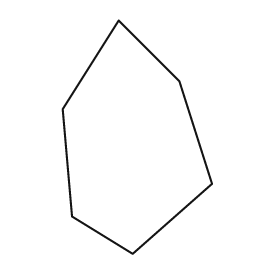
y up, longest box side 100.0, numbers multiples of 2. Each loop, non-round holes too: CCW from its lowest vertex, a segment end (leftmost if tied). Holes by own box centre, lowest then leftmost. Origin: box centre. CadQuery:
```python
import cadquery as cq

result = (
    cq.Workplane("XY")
    .moveTo(-2.0, -50.0)
    .lineTo(32.0, -20.0)
    .lineTo(18.0, 24.0)
    .lineTo(-8.0, 50.0)
    .lineTo(-32.0, 12.0)
    .lineTo(-28.0, -34.0)
    .close()
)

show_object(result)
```